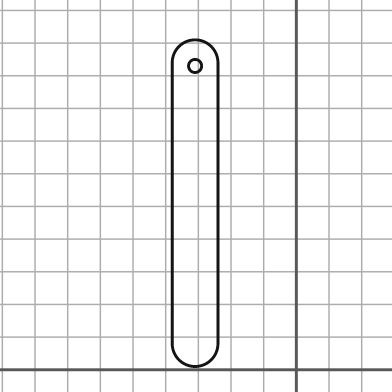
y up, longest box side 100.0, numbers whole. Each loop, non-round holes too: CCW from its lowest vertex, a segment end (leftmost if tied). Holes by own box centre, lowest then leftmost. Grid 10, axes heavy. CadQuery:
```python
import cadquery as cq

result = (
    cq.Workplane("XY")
    .moveTo(-38.0, 8.0)
    .threePointArc((-31.0, 1.0), (-24.0, 8.0))
    .lineTo(-24.0, 94.0)
    .threePointArc((-31.0, 101.0), (-38.0, 94.0))
    .close()
    .moveTo(-31.0, 93.0)
    .circle(2.0)
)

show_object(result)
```